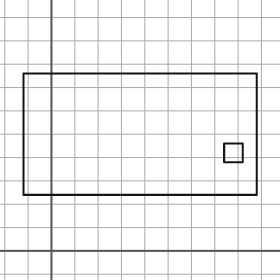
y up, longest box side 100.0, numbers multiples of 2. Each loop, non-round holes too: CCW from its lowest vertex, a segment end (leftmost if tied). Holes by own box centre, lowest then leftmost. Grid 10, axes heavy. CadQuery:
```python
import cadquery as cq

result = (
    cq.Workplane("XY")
    .moveTo(-12.0, 24.0)
    .lineTo(88.0, 24.0)
    .lineTo(88.0, 76.0)
    .lineTo(-12.0, 76.0)
    .close()
    .moveTo(74.0, 38.0)
    .lineTo(82.0, 38.0)
    .lineTo(82.0, 46.0)
    .lineTo(74.0, 46.0)
    .close()
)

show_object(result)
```